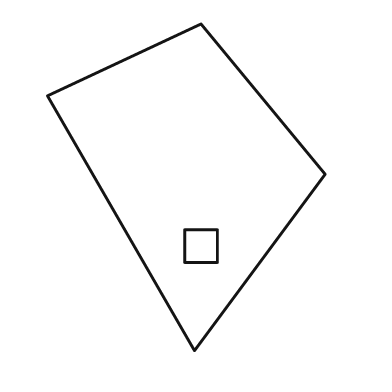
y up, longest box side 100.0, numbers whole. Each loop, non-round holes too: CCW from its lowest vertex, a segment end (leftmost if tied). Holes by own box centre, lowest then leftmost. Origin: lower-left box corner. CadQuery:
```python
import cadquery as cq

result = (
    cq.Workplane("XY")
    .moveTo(45.0, 0.0)
    .lineTo(85.0, 54.0)
    .lineTo(47.0, 100.0)
    .lineTo(0.0, 78.0)
    .close()
    .moveTo(42.0, 27.0)
    .lineTo(52.0, 27.0)
    .lineTo(52.0, 37.0)
    .lineTo(42.0, 37.0)
    .close()
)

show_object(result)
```